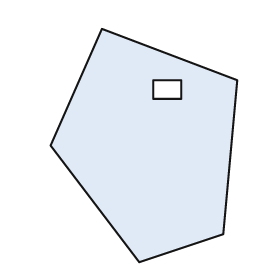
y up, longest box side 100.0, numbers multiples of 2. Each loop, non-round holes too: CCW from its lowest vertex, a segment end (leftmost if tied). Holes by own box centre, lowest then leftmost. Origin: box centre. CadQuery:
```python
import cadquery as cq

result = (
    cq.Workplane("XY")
    .moveTo(-2.0, -50.0)
    .lineTo(34.0, -38.0)
    .lineTo(40.0, 28.0)
    .lineTo(-18.0, 50.0)
    .lineTo(-40.0, 0.0)
    .close()
    .moveTo(4.0, 20.0)
    .lineTo(16.0, 20.0)
    .lineTo(16.0, 28.0)
    .lineTo(4.0, 28.0)
    .close()
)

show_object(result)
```